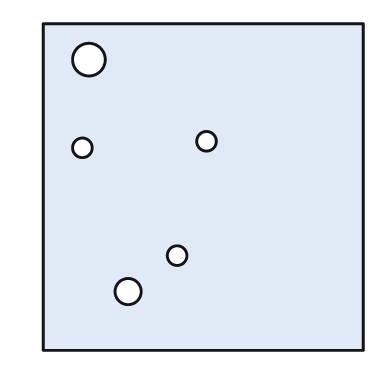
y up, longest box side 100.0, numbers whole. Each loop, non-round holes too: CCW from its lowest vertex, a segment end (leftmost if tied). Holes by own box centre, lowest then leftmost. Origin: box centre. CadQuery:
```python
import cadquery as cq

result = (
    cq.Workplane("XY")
    .moveTo(-49.0, -50.0)
    .lineTo(49.0, -50.0)
    .lineTo(49.0, 50.0)
    .lineTo(-49.0, 50.0)
    .close()
    .moveTo(-23.0, -32.0)
    .circle(4.0)
    .moveTo(-8.0, -21.0)
    .circle(3.0)
    .moveTo(-37.0, 12.0)
    .circle(3.0)
    .moveTo(1.0, 14.0)
    .circle(3.0)
    .moveTo(-35.0, 39.0)
    .circle(5.0)
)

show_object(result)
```